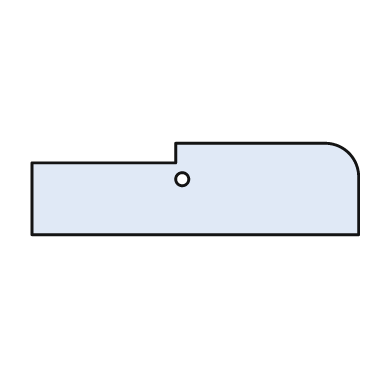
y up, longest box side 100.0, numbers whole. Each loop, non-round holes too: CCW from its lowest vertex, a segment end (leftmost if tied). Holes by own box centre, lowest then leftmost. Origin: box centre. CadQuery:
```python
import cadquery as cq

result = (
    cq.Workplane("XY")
    .moveTo(-50.0, -14.0)
    .lineTo(50.0, -14.0)
    .lineTo(50.0, 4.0)
    .threePointArc((47.0, 11.0), (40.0, 14.0))
    .lineTo(-6.0, 14.0)
    .lineTo(-6.0, 8.0)
    .lineTo(-50.0, 8.0)
    .close()
    .moveTo(-4.0, 3.0)
    .circle(2.0)
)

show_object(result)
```